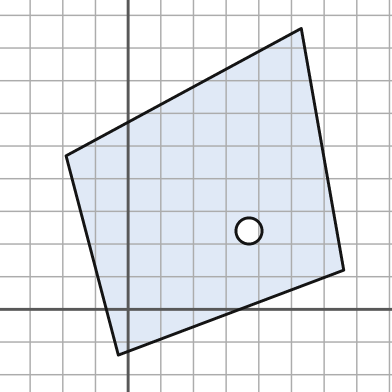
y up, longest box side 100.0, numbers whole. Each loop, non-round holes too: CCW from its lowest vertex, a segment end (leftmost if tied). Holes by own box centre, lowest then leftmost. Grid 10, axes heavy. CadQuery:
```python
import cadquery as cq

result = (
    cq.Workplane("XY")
    .moveTo(-3.0, -14.0)
    .lineTo(66.0, 12.0)
    .lineTo(53.0, 86.0)
    .lineTo(-19.0, 47.0)
    .close()
    .moveTo(37.0, 24.0)
    .circle(4.0)
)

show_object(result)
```